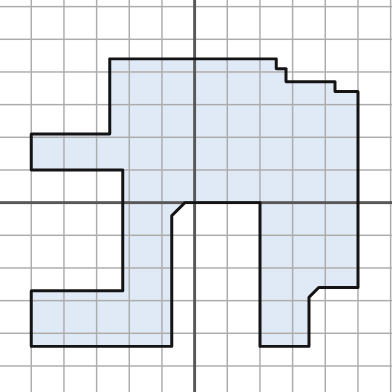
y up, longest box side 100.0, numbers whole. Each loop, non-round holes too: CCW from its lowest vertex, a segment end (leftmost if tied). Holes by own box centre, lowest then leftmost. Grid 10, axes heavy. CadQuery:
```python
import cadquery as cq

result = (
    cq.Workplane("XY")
    .moveTo(-50.0, -44.0)
    .lineTo(-7.0, -44.0)
    .lineTo(-7.0, -4.0)
    .lineTo(-3.0, 0.0)
    .lineTo(20.0, 0.0)
    .lineTo(20.0, -44.0)
    .lineTo(35.0, -44.0)
    .lineTo(35.0, -29.0)
    .lineTo(38.0, -26.0)
    .lineTo(50.0, -26.0)
    .lineTo(50.0, 34.0)
    .lineTo(43.0, 34.0)
    .lineTo(43.0, 37.0)
    .lineTo(28.0, 37.0)
    .lineTo(28.0, 41.0)
    .lineTo(25.0, 41.0)
    .lineTo(25.0, 44.0)
    .lineTo(-26.0, 44.0)
    .lineTo(-26.0, 21.0)
    .lineTo(-50.0, 21.0)
    .lineTo(-50.0, 10.0)
    .lineTo(-22.0, 10.0)
    .lineTo(-22.0, -27.0)
    .lineTo(-50.0, -27.0)
    .close()
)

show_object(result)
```